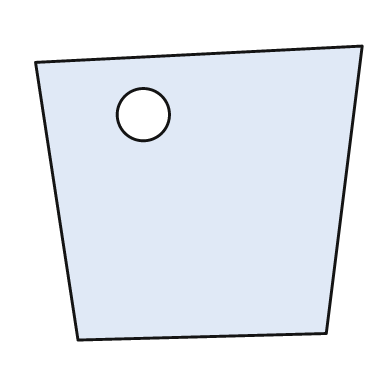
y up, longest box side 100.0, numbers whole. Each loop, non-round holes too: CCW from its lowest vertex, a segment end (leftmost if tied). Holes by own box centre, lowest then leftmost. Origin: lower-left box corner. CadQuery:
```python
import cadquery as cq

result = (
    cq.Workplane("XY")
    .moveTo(13.0, 0.0)
    .lineTo(89.0, 2.0)
    .lineTo(100.0, 90.0)
    .lineTo(0.0, 85.0)
    .close()
    .moveTo(33.0, 69.0)
    .circle(8.0)
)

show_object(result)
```